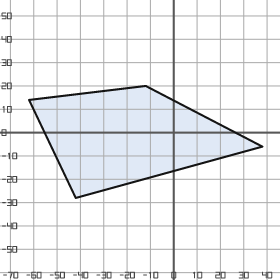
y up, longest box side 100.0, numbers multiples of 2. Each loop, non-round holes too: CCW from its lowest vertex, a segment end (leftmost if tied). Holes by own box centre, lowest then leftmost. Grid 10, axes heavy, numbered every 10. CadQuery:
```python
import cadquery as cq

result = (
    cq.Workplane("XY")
    .moveTo(-42.0, -28.0)
    .lineTo(38.0, -6.0)
    .lineTo(-12.0, 20.0)
    .lineTo(-62.0, 14.0)
    .close()
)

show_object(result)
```